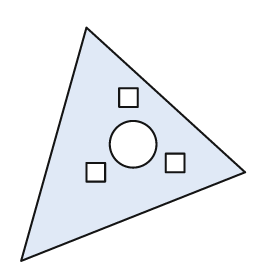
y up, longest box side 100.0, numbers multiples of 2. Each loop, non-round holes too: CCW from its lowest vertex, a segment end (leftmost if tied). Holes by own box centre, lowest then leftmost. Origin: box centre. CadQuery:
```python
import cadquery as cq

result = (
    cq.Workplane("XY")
    .moveTo(-48.0, -50.0)
    .lineTo(48.0, -12.0)
    .lineTo(-20.0, 50.0)
    .close()
    .moveTo(-20.0, -16.0)
    .lineTo(-12.0, -16.0)
    .lineTo(-12.0, -8.0)
    .lineTo(-20.0, -8.0)
    .close()
    .moveTo(14.0, -12.0)
    .lineTo(22.0, -12.0)
    .lineTo(22.0, -4.0)
    .lineTo(14.0, -4.0)
    .close()
    .moveTo(0.0, 0.0)
    .circle(10.0)
    .moveTo(-6.0, 16.0)
    .lineTo(2.0, 16.0)
    .lineTo(2.0, 24.0)
    .lineTo(-6.0, 24.0)
    .close()
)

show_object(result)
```